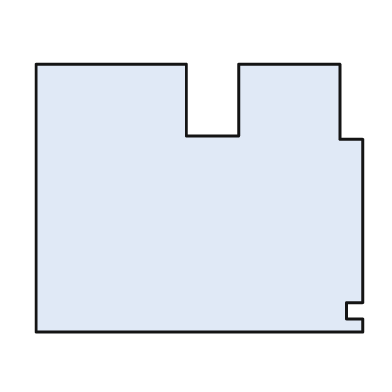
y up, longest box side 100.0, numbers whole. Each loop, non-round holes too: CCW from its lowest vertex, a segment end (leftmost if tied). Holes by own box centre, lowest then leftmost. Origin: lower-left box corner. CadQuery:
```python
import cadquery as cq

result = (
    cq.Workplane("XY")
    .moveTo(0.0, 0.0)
    .lineTo(100.0, 0.0)
    .lineTo(100.0, 4.0)
    .lineTo(95.0, 4.0)
    .lineTo(95.0, 9.0)
    .lineTo(100.0, 9.0)
    .lineTo(100.0, 59.0)
    .lineTo(93.0, 59.0)
    .lineTo(93.0, 82.0)
    .lineTo(62.0, 82.0)
    .lineTo(62.0, 60.0)
    .lineTo(46.0, 60.0)
    .lineTo(46.0, 82.0)
    .lineTo(0.0, 82.0)
    .close()
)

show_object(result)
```